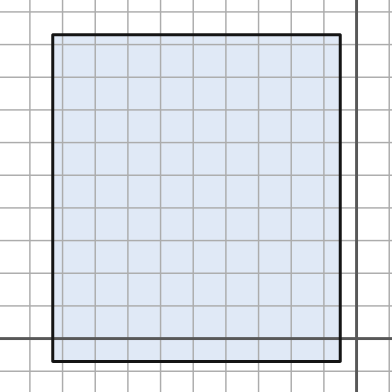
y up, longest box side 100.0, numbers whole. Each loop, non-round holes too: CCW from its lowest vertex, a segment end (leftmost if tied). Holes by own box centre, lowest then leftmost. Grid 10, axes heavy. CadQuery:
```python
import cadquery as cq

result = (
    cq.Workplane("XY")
    .moveTo(-93.0, -7.0)
    .lineTo(-5.0, -7.0)
    .lineTo(-5.0, 93.0)
    .lineTo(-93.0, 93.0)
    .close()
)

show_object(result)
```